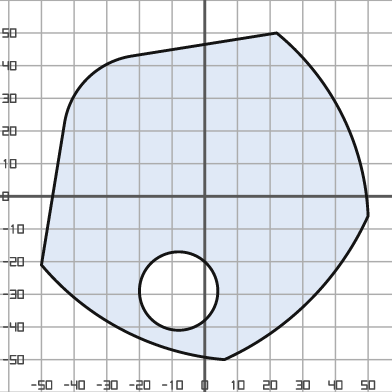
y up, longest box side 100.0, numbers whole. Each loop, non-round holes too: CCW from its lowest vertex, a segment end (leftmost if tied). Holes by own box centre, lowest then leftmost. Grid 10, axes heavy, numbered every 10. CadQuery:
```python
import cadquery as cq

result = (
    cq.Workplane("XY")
    .moveTo(6.0, -50.0)
    .threePointArc((32.0, -32.0), (50.0, -6.0))
    .threePointArc((42.0, 25.0), (22.0, 50.0))
    .lineTo(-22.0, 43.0)
    .threePointArc((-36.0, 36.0), (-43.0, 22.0))
    .lineTo(-50.0, -21.0)
    .threePointArc((-25.0, -41.0), (6.0, -50.0))
    .close()
    .moveTo(-8.0, -29.0)
    .circle(12.0)
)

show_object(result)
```